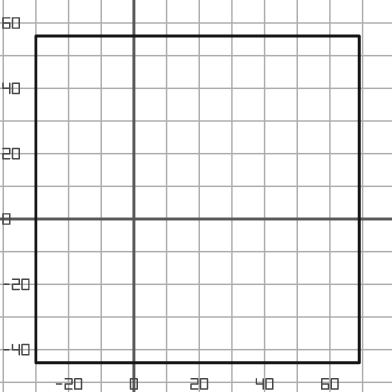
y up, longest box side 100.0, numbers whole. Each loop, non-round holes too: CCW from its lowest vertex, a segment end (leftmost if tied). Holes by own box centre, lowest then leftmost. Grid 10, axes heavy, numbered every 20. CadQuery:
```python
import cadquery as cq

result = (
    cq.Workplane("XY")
    .moveTo(-30.0, -44.0)
    .lineTo(69.0, -44.0)
    .lineTo(69.0, 56.0)
    .lineTo(-30.0, 56.0)
    .close()
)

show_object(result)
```